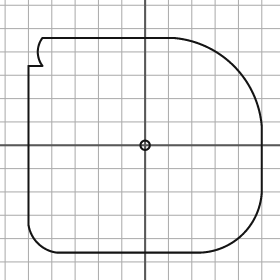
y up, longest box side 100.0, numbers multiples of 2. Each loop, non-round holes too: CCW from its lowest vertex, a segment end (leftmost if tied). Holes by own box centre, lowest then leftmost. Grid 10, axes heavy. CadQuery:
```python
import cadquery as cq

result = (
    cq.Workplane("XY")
    .moveTo(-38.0, -46.0)
    .lineTo(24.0, -46.0)
    .threePointArc((42.0, -38.0), (50.0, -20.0))
    .lineTo(50.0, 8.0)
    .threePointArc((38.0, 34.0), (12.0, 46.0))
    .lineTo(-44.0, 46.0)
    .threePointArc((-46.0, 40.0), (-44.0, 34.0))
    .lineTo(-50.0, 34.0)
    .lineTo(-50.0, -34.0)
    .threePointArc((-46.0, -42.0), (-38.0, -46.0))
    .close()
    .moveTo(0.0, 0.0)
    .circle(2.0)
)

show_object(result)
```